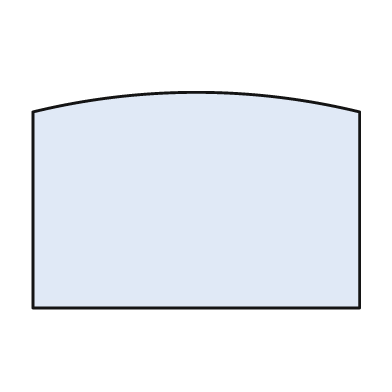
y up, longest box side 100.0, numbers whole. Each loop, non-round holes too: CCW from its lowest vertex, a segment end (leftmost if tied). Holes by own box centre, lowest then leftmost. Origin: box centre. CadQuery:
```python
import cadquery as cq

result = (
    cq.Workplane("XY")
    .moveTo(-50.0, -33.0)
    .lineTo(50.0, -33.0)
    .lineTo(50.0, 27.0)
    .threePointArc((0.0, 33.0), (-50.0, 27.0))
    .close()
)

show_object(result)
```